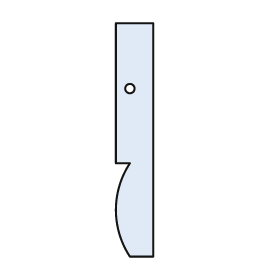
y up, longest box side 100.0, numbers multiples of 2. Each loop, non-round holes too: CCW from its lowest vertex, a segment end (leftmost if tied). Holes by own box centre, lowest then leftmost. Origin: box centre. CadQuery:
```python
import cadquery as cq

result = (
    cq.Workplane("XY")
    .moveTo(-2.0, -50.0)
    .lineTo(8.0, -50.0)
    .lineTo(8.0, 50.0)
    .lineTo(-8.0, 50.0)
    .lineTo(-8.0, -10.0)
    .lineTo(-2.0, -10.0)
    .threePointArc((-8.0, -30.0), (-2.0, -50.0))
    .close()
    .moveTo(-2.0, 22.0)
    .circle(2.0)
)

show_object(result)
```